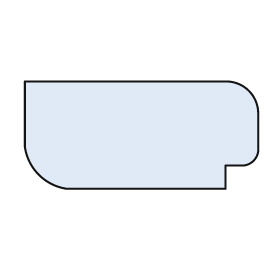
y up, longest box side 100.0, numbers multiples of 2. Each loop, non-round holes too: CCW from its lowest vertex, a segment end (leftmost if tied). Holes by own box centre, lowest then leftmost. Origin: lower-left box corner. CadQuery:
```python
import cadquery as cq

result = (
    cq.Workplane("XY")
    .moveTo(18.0, 0.0)
    .lineTo(86.0, 0.0)
    .lineTo(86.0, 10.0)
    .lineTo(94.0, 10.0)
    .threePointArc((98.0, 12.0), (100.0, 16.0))
    .lineTo(100.0, 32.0)
    .threePointArc((96.0, 42.0), (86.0, 46.0))
    .lineTo(0.0, 46.0)
    .lineTo(0.0, 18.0)
    .threePointArc((6.0, 6.0), (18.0, 0.0))
    .close()
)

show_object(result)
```